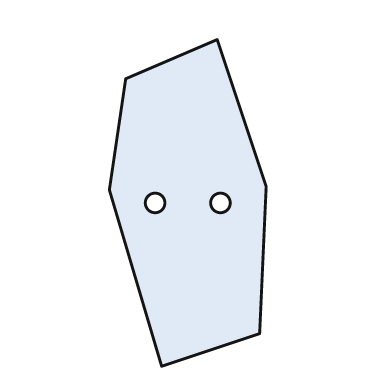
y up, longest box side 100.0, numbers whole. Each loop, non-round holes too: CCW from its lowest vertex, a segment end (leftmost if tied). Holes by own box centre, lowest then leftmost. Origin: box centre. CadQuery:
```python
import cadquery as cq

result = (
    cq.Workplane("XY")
    .moveTo(-8.0, -50.0)
    .lineTo(22.0, -40.0)
    .lineTo(24.0, 5.0)
    .lineTo(9.0, 50.0)
    .lineTo(-19.0, 38.0)
    .lineTo(-24.0, 4.0)
    .close()
    .moveTo(-10.0, 0.0)
    .circle(3.0)
    .moveTo(10.0, 0.0)
    .circle(3.0)
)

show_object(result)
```